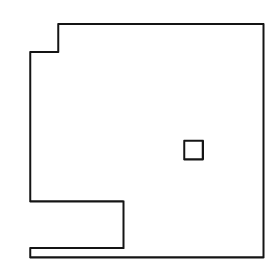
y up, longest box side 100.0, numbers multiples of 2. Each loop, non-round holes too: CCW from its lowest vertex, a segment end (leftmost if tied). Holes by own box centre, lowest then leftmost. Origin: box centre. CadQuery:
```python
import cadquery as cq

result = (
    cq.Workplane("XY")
    .moveTo(-50.0, -50.0)
    .lineTo(50.0, -50.0)
    .lineTo(50.0, 50.0)
    .lineTo(-38.0, 50.0)
    .lineTo(-38.0, 38.0)
    .lineTo(-50.0, 38.0)
    .lineTo(-50.0, -26.0)
    .lineTo(-10.0, -26.0)
    .lineTo(-10.0, -46.0)
    .lineTo(-50.0, -46.0)
    .close()
    .moveTo(16.0, -8.0)
    .lineTo(24.0, -8.0)
    .lineTo(24.0, 0.0)
    .lineTo(16.0, 0.0)
    .close()
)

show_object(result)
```